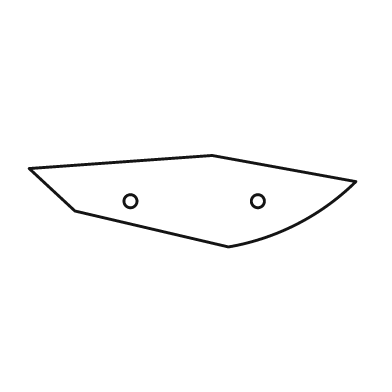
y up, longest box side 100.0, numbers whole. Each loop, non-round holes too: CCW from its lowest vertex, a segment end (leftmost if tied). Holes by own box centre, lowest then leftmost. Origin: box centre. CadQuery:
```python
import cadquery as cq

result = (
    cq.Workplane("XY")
    .moveTo(11.0, -14.0)
    .threePointArc((32.0, -7.0), (50.0, 6.0))
    .lineTo(6.0, 14.0)
    .lineTo(-50.0, 10.0)
    .lineTo(-36.0, -3.0)
    .close()
    .moveTo(-19.0, 0.0)
    .circle(2.0)
    .moveTo(20.0, 0.0)
    .circle(2.0)
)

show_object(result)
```